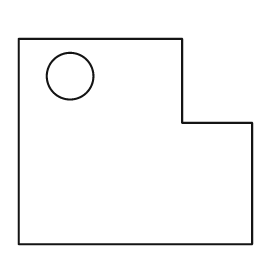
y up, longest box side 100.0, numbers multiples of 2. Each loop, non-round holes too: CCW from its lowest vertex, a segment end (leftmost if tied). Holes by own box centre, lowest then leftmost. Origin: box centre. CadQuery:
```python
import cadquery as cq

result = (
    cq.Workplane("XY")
    .moveTo(-50.0, -44.0)
    .lineTo(50.0, -44.0)
    .lineTo(50.0, 8.0)
    .lineTo(20.0, 8.0)
    .lineTo(20.0, 44.0)
    .lineTo(-50.0, 44.0)
    .close()
    .moveTo(-28.0, 28.0)
    .circle(10.0)
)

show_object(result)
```